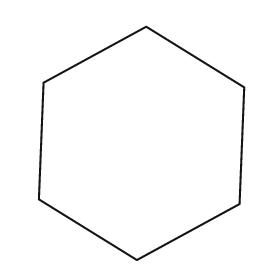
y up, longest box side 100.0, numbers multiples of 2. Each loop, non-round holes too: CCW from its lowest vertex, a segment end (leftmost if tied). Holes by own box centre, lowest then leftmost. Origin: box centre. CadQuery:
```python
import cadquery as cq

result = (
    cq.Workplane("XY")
    .moveTo(-2.0, -50.0)
    .lineTo(42.0, -26.0)
    .lineTo(44.0, 24.0)
    .lineTo(2.0, 50.0)
    .lineTo(-42.0, 26.0)
    .lineTo(-44.0, -24.0)
    .close()
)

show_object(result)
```